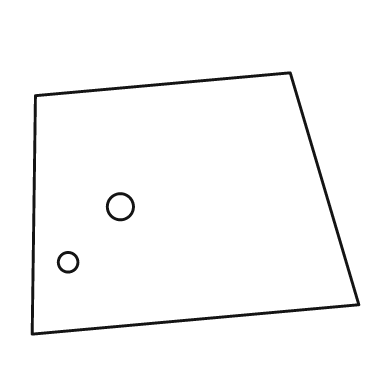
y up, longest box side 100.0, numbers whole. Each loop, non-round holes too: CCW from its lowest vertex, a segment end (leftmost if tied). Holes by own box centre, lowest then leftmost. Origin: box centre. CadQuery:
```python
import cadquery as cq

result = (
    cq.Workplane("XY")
    .moveTo(-50.0, -40.0)
    .lineTo(50.0, -31.0)
    .lineTo(29.0, 40.0)
    .lineTo(-49.0, 33.0)
    .close()
    .moveTo(-39.0, -18.0)
    .circle(3.0)
    .moveTo(-23.0, -1.0)
    .circle(4.0)
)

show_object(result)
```